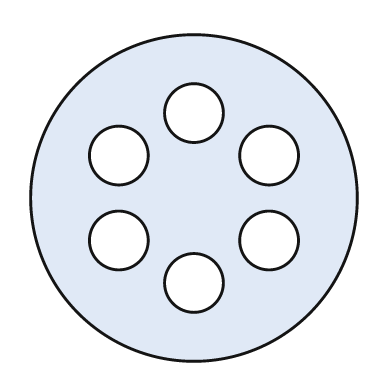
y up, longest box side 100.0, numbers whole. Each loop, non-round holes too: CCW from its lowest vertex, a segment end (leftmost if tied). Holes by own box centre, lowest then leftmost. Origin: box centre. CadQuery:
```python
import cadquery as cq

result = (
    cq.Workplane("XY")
    .moveTo(0.0, 0.0)
    .circle(50.0)
    .moveTo(0.0, -26.0)
    .circle(9.0)
    .moveTo(-23.0, -13.0)
    .circle(9.0)
    .moveTo(23.0, -13.0)
    .circle(9.0)
    .moveTo(-23.0, 13.0)
    .circle(9.0)
    .moveTo(23.0, 13.0)
    .circle(9.0)
    .moveTo(0.0, 26.0)
    .circle(9.0)
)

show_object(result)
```